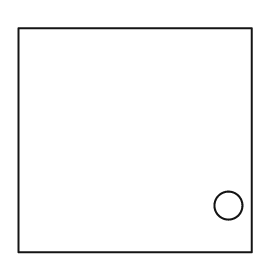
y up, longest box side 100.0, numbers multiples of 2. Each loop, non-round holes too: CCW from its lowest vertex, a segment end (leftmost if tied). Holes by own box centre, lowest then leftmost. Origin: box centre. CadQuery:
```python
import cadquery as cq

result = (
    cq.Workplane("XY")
    .moveTo(-50.0, -48.0)
    .lineTo(50.0, -48.0)
    .lineTo(50.0, 48.0)
    .lineTo(-50.0, 48.0)
    .close()
    .moveTo(40.0, -28.0)
    .circle(6.0)
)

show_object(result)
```